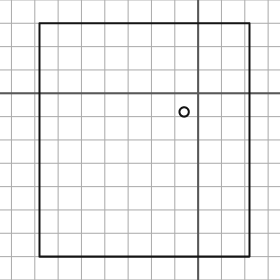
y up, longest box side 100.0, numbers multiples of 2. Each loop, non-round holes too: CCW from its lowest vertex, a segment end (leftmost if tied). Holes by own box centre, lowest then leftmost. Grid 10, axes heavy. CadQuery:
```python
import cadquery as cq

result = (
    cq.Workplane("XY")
    .moveTo(-68.0, -70.0)
    .lineTo(22.0, -70.0)
    .lineTo(22.0, 30.0)
    .lineTo(-68.0, 30.0)
    .close()
    .moveTo(-6.0, -8.0)
    .circle(2.0)
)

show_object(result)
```